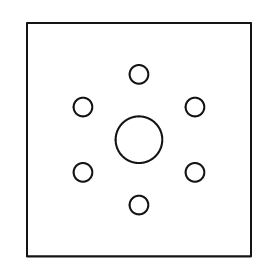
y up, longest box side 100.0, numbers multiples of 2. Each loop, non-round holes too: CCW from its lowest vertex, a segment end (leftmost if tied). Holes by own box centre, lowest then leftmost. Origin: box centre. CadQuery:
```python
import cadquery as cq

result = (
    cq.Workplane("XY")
    .moveTo(-48.0, -50.0)
    .lineTo(48.0, -50.0)
    .lineTo(48.0, 50.0)
    .lineTo(-48.0, 50.0)
    .close()
    .moveTo(0.0, -28.0)
    .circle(4.0)
    .moveTo(-24.0, -14.0)
    .circle(4.0)
    .moveTo(24.0, -14.0)
    .circle(4.0)
    .moveTo(0.0, 0.0)
    .circle(10.0)
    .moveTo(-24.0, 14.0)
    .circle(4.0)
    .moveTo(24.0, 14.0)
    .circle(4.0)
    .moveTo(0.0, 28.0)
    .circle(4.0)
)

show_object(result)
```